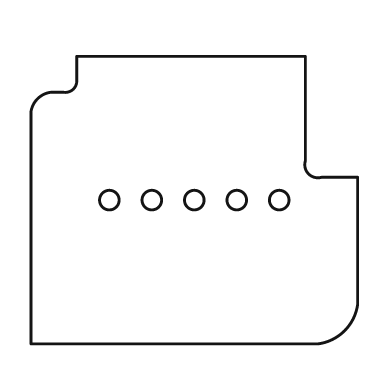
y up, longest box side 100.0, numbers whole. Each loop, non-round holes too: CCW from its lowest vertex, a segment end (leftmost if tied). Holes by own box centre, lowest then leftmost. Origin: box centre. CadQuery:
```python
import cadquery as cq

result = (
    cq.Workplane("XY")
    .moveTo(-50.0, -44.0)
    .lineTo(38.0, -44.0)
    .threePointArc((46.0, -40.0), (50.0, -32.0))
    .lineTo(50.0, 7.0)
    .lineTo(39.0, 7.0)
    .threePointArc((35.0, 8.0), (34.0, 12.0))
    .lineTo(34.0, 44.0)
    .lineTo(-36.0, 44.0)
    .lineTo(-36.0, 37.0)
    .threePointArc((-37.0, 34.0), (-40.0, 33.0))
    .lineTo(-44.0, 33.0)
    .threePointArc((-48.0, 31.0), (-50.0, 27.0))
    .close()
    .moveTo(-26.0, 0.0)
    .circle(3.0)
    .moveTo(-13.0, 0.0)
    .circle(3.0)
    .moveTo(0.0, 0.0)
    .circle(3.0)
    .moveTo(13.0, 0.0)
    .circle(3.0)
    .moveTo(26.0, 0.0)
    .circle(3.0)
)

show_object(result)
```